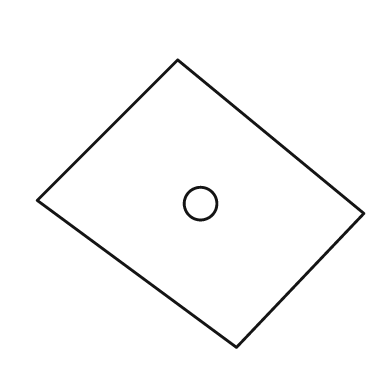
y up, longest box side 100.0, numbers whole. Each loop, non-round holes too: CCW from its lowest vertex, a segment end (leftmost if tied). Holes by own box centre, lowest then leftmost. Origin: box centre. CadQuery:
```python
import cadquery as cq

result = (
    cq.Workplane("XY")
    .moveTo(11.0, -44.0)
    .lineTo(50.0, -3.0)
    .lineTo(-7.0, 44.0)
    .lineTo(-50.0, 1.0)
    .close()
    .moveTo(0.0, 0.0)
    .circle(5.0)
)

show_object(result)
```